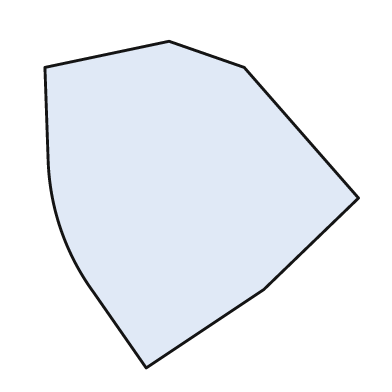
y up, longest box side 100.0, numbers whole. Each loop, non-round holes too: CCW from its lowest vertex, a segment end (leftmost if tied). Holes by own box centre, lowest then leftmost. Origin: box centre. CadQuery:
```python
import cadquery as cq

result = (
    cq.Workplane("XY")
    .moveTo(-17.0, -50.0)
    .lineTo(19.0, -26.0)
    .lineTo(48.0, 2.0)
    .lineTo(13.0, 42.0)
    .lineTo(-10.0, 50.0)
    .lineTo(-48.0, 42.0)
    .lineTo(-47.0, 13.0)
    .threePointArc((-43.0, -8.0), (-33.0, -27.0))
    .close()
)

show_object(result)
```